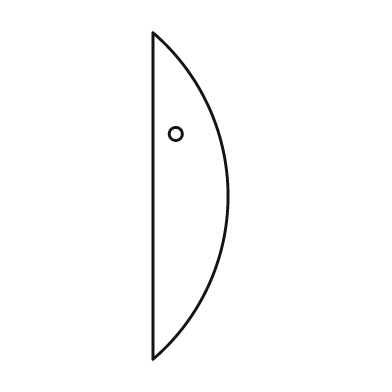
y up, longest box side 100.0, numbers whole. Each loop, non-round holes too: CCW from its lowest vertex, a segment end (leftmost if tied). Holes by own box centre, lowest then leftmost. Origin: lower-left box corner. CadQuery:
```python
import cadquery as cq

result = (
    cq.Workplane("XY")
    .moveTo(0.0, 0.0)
    .threePointArc((23.0, 50.0), (0.0, 100.0))
    .close()
    .moveTo(7.0, 69.0)
    .circle(2.0)
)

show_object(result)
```